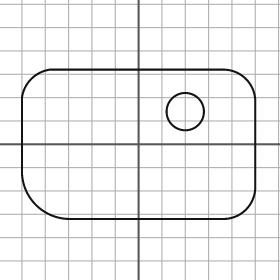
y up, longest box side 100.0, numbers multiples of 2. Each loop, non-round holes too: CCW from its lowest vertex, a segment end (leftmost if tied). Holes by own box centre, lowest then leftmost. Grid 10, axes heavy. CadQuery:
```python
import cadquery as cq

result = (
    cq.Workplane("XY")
    .moveTo(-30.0, -32.0)
    .lineTo(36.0, -32.0)
    .threePointArc((46.0, -28.0), (50.0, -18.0))
    .lineTo(50.0, 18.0)
    .threePointArc((46.0, 28.0), (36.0, 32.0))
    .lineTo(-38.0, 32.0)
    .threePointArc((-46.0, 28.0), (-50.0, 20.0))
    .lineTo(-50.0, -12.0)
    .threePointArc((-44.0, -26.0), (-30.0, -32.0))
    .close()
    .moveTo(20.0, 14.0)
    .circle(8.0)
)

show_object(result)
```